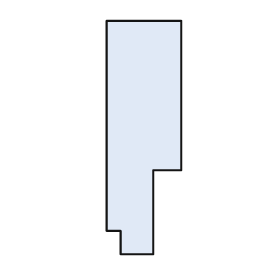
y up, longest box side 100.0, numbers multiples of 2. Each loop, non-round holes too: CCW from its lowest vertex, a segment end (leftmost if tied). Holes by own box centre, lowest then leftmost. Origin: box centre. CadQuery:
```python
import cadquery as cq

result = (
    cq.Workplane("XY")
    .moveTo(-10.0, -50.0)
    .lineTo(4.0, -50.0)
    .lineTo(4.0, -14.0)
    .lineTo(16.0, -14.0)
    .lineTo(16.0, 50.0)
    .lineTo(-16.0, 50.0)
    .lineTo(-16.0, -40.0)
    .lineTo(-10.0, -40.0)
    .close()
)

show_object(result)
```